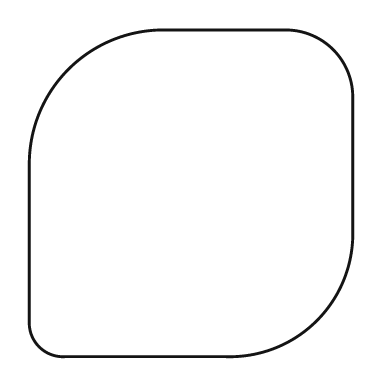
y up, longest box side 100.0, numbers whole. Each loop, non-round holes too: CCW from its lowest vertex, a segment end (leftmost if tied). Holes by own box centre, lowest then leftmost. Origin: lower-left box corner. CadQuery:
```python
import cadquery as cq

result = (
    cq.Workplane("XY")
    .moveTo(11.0, 0.0)
    .lineTo(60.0, 0.0)
    .threePointArc((88.0, 11.0), (99.0, 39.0))
    .lineTo(99.0, 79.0)
    .threePointArc((93.0, 94.0), (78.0, 100.0))
    .lineTo(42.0, 100.0)
    .threePointArc((12.0, 88.0), (0.0, 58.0))
    .lineTo(0.0, 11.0)
    .threePointArc((3.0, 3.0), (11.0, 0.0))
    .close()
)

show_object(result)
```